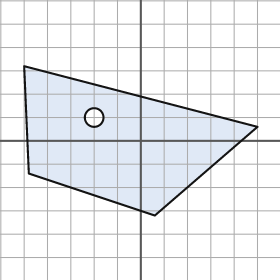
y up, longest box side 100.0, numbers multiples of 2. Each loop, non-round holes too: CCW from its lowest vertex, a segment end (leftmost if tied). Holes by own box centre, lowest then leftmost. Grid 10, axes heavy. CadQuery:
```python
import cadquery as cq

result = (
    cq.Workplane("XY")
    .moveTo(6.0, -32.0)
    .lineTo(50.0, 6.0)
    .lineTo(-50.0, 32.0)
    .lineTo(-48.0, -14.0)
    .close()
    .moveTo(-20.0, 10.0)
    .circle(4.0)
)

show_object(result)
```